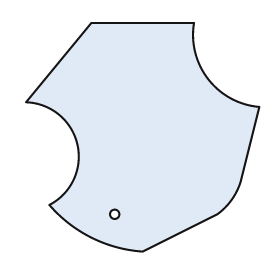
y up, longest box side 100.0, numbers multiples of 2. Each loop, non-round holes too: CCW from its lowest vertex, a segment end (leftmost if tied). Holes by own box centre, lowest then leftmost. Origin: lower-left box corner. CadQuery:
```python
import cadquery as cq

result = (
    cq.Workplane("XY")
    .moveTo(50.0, 0.0)
    .lineTo(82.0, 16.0)
    .threePointArc((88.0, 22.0), (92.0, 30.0))
    .lineTo(100.0, 62.0)
    .threePointArc((78.0, 74.0), (72.0, 98.0))
    .lineTo(28.0, 98.0)
    .lineTo(0.0, 64.0)
    .threePointArc((22.0, 46.0), (10.0, 20.0))
    .threePointArc((28.0, 6.0), (50.0, 0.0))
    .close()
    .moveTo(38.0, 16.0)
    .circle(2.0)
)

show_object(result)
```